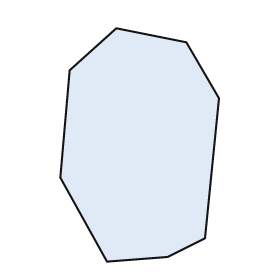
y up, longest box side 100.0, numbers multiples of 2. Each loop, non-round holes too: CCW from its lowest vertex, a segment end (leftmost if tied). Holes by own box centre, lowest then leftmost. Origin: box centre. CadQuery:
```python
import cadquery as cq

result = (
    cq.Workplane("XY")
    .moveTo(-14.0, -50.0)
    .lineTo(12.0, -48.0)
    .lineTo(28.0, -40.0)
    .lineTo(34.0, 20.0)
    .lineTo(20.0, 44.0)
    .lineTo(-10.0, 50.0)
    .lineTo(-30.0, 32.0)
    .lineTo(-34.0, -14.0)
    .close()
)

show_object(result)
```